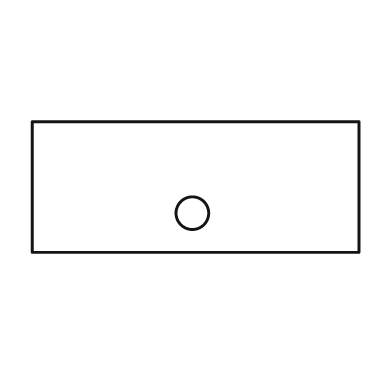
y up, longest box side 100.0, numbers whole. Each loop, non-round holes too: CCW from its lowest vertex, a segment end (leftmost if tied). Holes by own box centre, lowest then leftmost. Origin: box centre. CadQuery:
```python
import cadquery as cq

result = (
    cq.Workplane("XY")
    .moveTo(-50.0, -20.0)
    .lineTo(50.0, -20.0)
    .lineTo(50.0, 20.0)
    .lineTo(-50.0, 20.0)
    .close()
    .moveTo(-1.0, -8.0)
    .circle(5.0)
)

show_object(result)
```